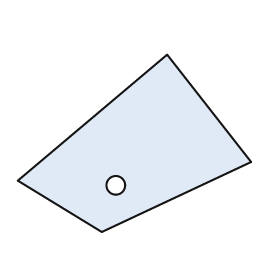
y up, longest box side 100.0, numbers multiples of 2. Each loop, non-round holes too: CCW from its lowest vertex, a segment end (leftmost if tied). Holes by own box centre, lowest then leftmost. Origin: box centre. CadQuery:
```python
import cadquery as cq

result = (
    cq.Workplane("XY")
    .moveTo(-14.0, -38.0)
    .lineTo(50.0, -8.0)
    .lineTo(14.0, 38.0)
    .lineTo(-50.0, -16.0)
    .close()
    .moveTo(-8.0, -18.0)
    .circle(4.0)
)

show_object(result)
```